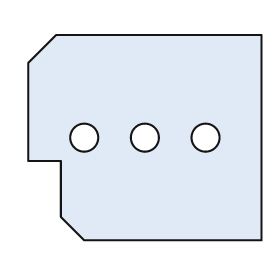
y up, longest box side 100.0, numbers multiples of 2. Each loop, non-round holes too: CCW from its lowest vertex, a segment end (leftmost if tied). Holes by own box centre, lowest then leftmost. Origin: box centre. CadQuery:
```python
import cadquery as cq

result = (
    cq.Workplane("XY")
    .moveTo(-26.0, -44.0)
    .lineTo(50.0, -44.0)
    .lineTo(50.0, 44.0)
    .lineTo(-38.0, 44.0)
    .lineTo(-50.0, 32.0)
    .lineTo(-50.0, -10.0)
    .lineTo(-36.0, -10.0)
    .lineTo(-36.0, -34.0)
    .close()
    .moveTo(-26.0, 0.0)
    .circle(6.0)
    .moveTo(0.0, 0.0)
    .circle(6.0)
    .moveTo(26.0, 0.0)
    .circle(6.0)
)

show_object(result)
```